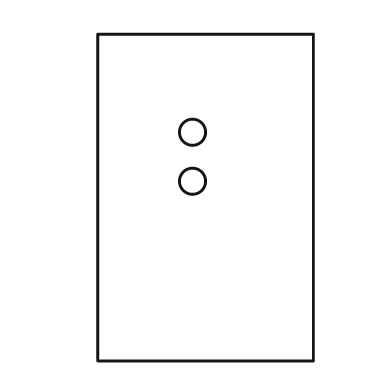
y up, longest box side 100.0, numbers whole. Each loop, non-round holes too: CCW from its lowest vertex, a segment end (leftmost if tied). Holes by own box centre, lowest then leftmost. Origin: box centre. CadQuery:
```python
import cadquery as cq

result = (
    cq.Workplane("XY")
    .moveTo(-33.0, -50.0)
    .lineTo(33.0, -50.0)
    .lineTo(33.0, 50.0)
    .lineTo(-33.0, 50.0)
    .close()
    .moveTo(-4.0, 5.0)
    .circle(4.0)
    .moveTo(-4.0, 20.0)
    .circle(4.0)
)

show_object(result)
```